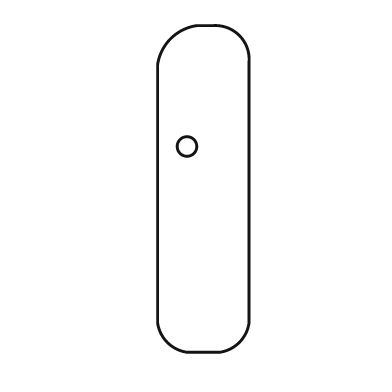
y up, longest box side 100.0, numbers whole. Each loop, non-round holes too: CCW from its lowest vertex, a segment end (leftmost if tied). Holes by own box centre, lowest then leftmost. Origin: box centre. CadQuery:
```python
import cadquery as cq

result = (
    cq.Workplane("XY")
    .moveTo(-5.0, -50.0)
    .lineTo(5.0, -50.0)
    .threePointArc((11.0, -47.0), (14.0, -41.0))
    .lineTo(14.0, 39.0)
    .threePointArc((11.0, 47.0), (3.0, 50.0))
    .lineTo(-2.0, 50.0)
    .threePointArc((-10.0, 46.0), (-14.0, 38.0))
    .lineTo(-14.0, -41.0)
    .threePointArc((-11.0, -47.0), (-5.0, -50.0))
    .close()
    .moveTo(-5.0, 13.0)
    .circle(3.0)
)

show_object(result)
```